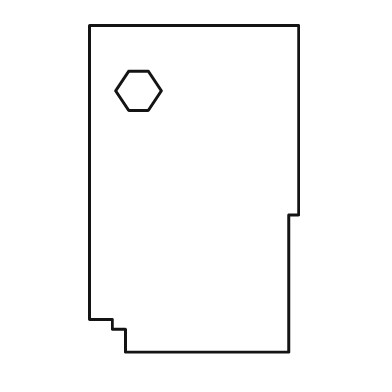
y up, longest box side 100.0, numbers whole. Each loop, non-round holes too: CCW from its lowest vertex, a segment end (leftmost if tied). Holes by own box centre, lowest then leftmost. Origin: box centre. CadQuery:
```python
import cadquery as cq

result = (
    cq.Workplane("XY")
    .moveTo(-21.0, -50.0)
    .lineTo(29.0, -50.0)
    .lineTo(29.0, -8.0)
    .lineTo(32.0, -8.0)
    .lineTo(32.0, 50.0)
    .lineTo(-32.0, 50.0)
    .lineTo(-32.0, -40.0)
    .lineTo(-25.0, -40.0)
    .lineTo(-25.0, -43.0)
    .lineTo(-21.0, -43.0)
    .close()
    .moveTo(-20.0, 24.0)
    .lineTo(-14.0, 24.0)
    .lineTo(-10.0, 30.0)
    .lineTo(-14.0, 36.0)
    .lineTo(-20.0, 36.0)
    .lineTo(-24.0, 30.0)
    .close()
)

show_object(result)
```